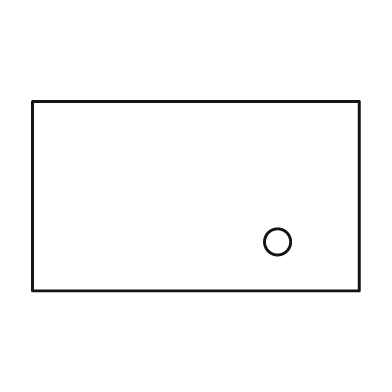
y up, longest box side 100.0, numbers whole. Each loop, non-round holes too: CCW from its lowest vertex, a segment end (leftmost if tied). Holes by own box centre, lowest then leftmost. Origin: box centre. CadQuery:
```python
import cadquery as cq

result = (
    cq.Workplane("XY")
    .moveTo(-50.0, -29.0)
    .lineTo(50.0, -29.0)
    .lineTo(50.0, 29.0)
    .lineTo(-50.0, 29.0)
    .close()
    .moveTo(25.0, -14.0)
    .circle(4.0)
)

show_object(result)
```